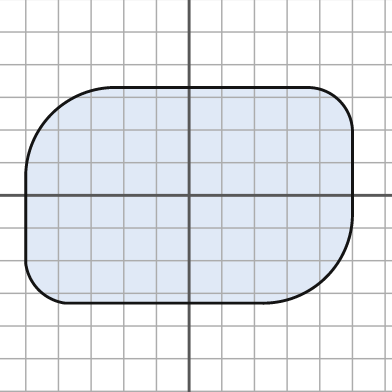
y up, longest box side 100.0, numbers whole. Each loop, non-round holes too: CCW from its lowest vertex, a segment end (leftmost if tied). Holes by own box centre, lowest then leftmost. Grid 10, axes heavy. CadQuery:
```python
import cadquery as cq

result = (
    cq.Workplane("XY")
    .moveTo(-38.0, -33.0)
    .lineTo(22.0, -33.0)
    .threePointArc((42.0, -25.0), (50.0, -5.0))
    .lineTo(50.0, 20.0)
    .threePointArc((46.0, 29.0), (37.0, 33.0))
    .lineTo(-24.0, 33.0)
    .threePointArc((-42.0, 25.0), (-50.0, 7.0))
    .lineTo(-50.0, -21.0)
    .threePointArc((-46.0, -29.0), (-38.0, -33.0))
    .close()
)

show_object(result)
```